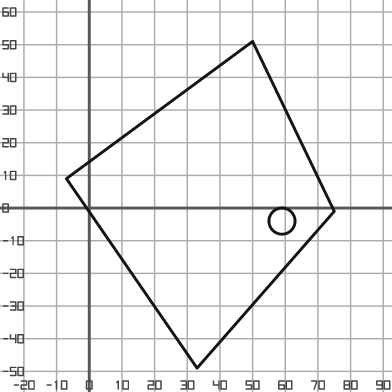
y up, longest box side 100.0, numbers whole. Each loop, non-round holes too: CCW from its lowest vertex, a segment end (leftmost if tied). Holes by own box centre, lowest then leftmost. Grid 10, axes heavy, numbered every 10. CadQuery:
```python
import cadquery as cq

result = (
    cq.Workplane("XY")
    .moveTo(33.0, -49.0)
    .lineTo(75.0, -1.0)
    .lineTo(50.0, 51.0)
    .lineTo(-7.0, 9.0)
    .close()
    .moveTo(59.0, -4.0)
    .circle(4.0)
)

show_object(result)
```